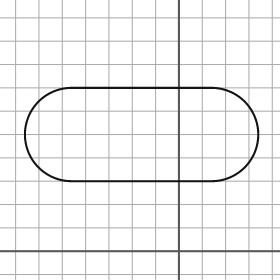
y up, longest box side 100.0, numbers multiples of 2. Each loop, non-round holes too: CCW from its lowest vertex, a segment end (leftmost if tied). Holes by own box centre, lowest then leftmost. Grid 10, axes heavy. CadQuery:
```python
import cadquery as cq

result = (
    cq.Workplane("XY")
    .moveTo(-46.0, 30.0)
    .lineTo(14.0, 30.0)
    .threePointArc((34.0, 50.0), (14.0, 70.0))
    .lineTo(-46.0, 70.0)
    .threePointArc((-66.0, 50.0), (-46.0, 30.0))
    .close()
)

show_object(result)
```